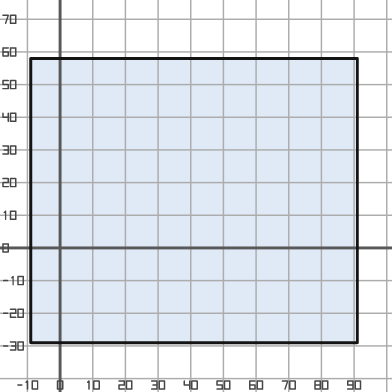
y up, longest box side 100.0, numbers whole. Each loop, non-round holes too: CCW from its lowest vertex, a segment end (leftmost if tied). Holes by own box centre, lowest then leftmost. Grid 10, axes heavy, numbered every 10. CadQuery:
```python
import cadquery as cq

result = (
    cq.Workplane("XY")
    .moveTo(-9.0, -29.0)
    .lineTo(91.0, -29.0)
    .lineTo(91.0, 58.0)
    .lineTo(-9.0, 58.0)
    .close()
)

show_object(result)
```